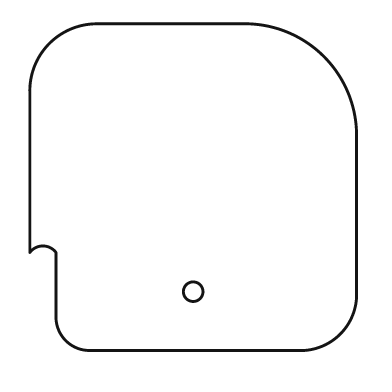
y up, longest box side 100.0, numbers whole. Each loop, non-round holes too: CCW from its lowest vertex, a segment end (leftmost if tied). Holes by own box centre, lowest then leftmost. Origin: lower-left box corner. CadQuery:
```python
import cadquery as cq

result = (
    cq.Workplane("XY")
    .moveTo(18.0, 0.0)
    .lineTo(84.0, 0.0)
    .threePointArc((95.0, 5.0), (100.0, 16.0))
    .lineTo(100.0, 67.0)
    .threePointArc((90.0, 90.0), (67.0, 100.0))
    .lineTo(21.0, 100.0)
    .threePointArc((6.0, 94.0), (0.0, 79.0))
    .lineTo(0.0, 30.0)
    .threePointArc((4.0, 32.0), (8.0, 30.0))
    .lineTo(8.0, 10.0)
    .threePointArc((11.0, 3.0), (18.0, 0.0))
    .close()
    .moveTo(50.0, 18.0)
    .circle(3.0)
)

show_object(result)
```